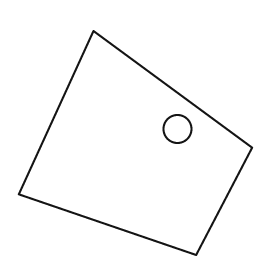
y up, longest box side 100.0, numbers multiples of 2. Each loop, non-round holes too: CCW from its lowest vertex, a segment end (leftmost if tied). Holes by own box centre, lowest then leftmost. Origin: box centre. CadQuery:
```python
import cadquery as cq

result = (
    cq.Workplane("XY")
    .moveTo(26.0, -48.0)
    .lineTo(50.0, -2.0)
    .lineTo(-18.0, 48.0)
    .lineTo(-50.0, -22.0)
    .close()
    .moveTo(18.0, 6.0)
    .circle(6.0)
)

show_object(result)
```